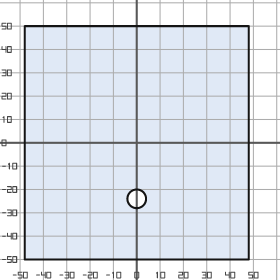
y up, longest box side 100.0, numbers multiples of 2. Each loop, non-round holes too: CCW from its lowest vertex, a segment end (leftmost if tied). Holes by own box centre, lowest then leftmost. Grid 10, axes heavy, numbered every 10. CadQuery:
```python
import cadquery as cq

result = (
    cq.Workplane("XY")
    .moveTo(-48.0, -50.0)
    .lineTo(48.0, -50.0)
    .lineTo(48.0, 50.0)
    .lineTo(-48.0, 50.0)
    .close()
    .moveTo(0.0, -24.0)
    .circle(4.0)
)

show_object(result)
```